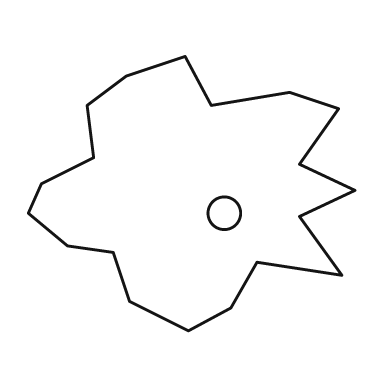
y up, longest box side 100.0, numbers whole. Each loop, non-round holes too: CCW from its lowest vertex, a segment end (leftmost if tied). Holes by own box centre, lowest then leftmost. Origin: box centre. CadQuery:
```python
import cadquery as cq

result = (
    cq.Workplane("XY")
    .moveTo(-1.0, -42.0)
    .lineTo(12.0, -35.0)
    .lineTo(20.0, -21.0)
    .lineTo(46.0, -25.0)
    .lineTo(33.0, -7.0)
    .lineTo(50.0, 1.0)
    .lineTo(33.0, 9.0)
    .lineTo(45.0, 26.0)
    .lineTo(30.0, 31.0)
    .lineTo(6.0, 27.0)
    .lineTo(-2.0, 42.0)
    .lineTo(-20.0, 36.0)
    .lineTo(-32.0, 27.0)
    .lineTo(-30.0, 11.0)
    .lineTo(-46.0, 3.0)
    .lineTo(-50.0, -6.0)
    .lineTo(-38.0, -16.0)
    .lineTo(-24.0, -18.0)
    .lineTo(-19.0, -33.0)
    .close()
    .moveTo(10.0, -6.0)
    .circle(5.0)
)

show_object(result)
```